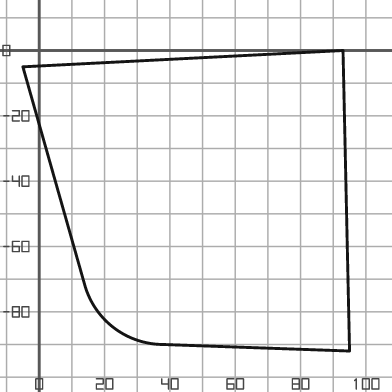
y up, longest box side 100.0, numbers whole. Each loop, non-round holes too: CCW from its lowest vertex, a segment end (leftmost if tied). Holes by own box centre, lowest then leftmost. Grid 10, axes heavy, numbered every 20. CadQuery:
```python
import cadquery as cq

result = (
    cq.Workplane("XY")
    .moveTo(95.0, -92.0)
    .lineTo(93.0, 0.0)
    .lineTo(-5.0, -5.0)
    .lineTo(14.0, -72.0)
    .threePointArc((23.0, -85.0), (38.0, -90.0))
    .close()
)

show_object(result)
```